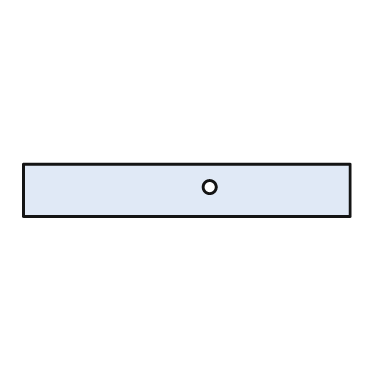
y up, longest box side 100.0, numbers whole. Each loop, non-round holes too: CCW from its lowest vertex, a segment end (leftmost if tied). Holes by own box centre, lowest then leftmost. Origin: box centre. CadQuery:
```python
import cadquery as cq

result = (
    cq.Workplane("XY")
    .moveTo(-50.0, -8.0)
    .lineTo(50.0, -8.0)
    .lineTo(50.0, 8.0)
    .lineTo(-50.0, 8.0)
    .close()
    .moveTo(7.0, 1.0)
    .circle(2.0)
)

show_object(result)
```